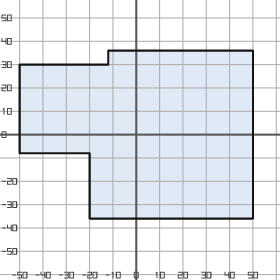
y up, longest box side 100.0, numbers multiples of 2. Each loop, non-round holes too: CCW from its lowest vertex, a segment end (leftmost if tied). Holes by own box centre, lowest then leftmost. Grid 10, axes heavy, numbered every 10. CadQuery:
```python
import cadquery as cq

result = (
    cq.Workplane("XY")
    .moveTo(-20.0, -36.0)
    .lineTo(50.0, -36.0)
    .lineTo(50.0, 36.0)
    .lineTo(-12.0, 36.0)
    .lineTo(-12.0, 30.0)
    .lineTo(-50.0, 30.0)
    .lineTo(-50.0, -8.0)
    .lineTo(-20.0, -8.0)
    .close()
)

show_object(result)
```